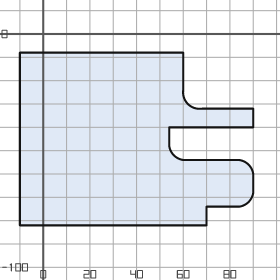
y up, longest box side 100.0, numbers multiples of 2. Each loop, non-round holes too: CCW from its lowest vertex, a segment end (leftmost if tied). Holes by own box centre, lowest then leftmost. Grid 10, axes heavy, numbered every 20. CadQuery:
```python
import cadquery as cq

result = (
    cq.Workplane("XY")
    .moveTo(-10.0, -82.0)
    .lineTo(70.0, -82.0)
    .lineTo(70.0, -74.0)
    .lineTo(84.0, -74.0)
    .threePointArc((88.0, -72.0), (90.0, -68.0))
    .lineTo(90.0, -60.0)
    .threePointArc((88.0, -56.0), (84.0, -54.0))
    .lineTo(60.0, -54.0)
    .threePointArc((56.0, -52.0), (54.0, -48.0))
    .lineTo(54.0, -40.0)
    .lineTo(90.0, -40.0)
    .lineTo(90.0, -32.0)
    .lineTo(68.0, -32.0)
    .threePointArc((62.0, -30.0), (60.0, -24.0))
    .lineTo(60.0, -8.0)
    .lineTo(-10.0, -8.0)
    .close()
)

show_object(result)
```